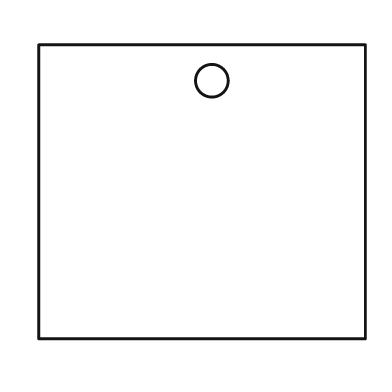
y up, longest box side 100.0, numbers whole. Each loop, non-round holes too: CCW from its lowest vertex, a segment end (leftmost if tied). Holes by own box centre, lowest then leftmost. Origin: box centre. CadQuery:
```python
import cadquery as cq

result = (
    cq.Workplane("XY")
    .moveTo(-50.0, -45.0)
    .lineTo(50.0, -45.0)
    .lineTo(50.0, 45.0)
    .lineTo(-50.0, 45.0)
    .close()
    .moveTo(3.0, 34.0)
    .circle(5.0)
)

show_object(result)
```